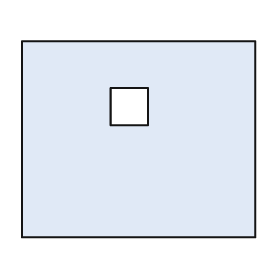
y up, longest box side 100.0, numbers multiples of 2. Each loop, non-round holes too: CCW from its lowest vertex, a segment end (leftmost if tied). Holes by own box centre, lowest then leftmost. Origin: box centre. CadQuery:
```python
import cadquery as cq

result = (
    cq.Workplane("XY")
    .moveTo(-50.0, -42.0)
    .lineTo(50.0, -42.0)
    .lineTo(50.0, 42.0)
    .lineTo(-50.0, 42.0)
    .close()
    .moveTo(-12.0, 6.0)
    .lineTo(4.0, 6.0)
    .lineTo(4.0, 22.0)
    .lineTo(-12.0, 22.0)
    .close()
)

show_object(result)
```